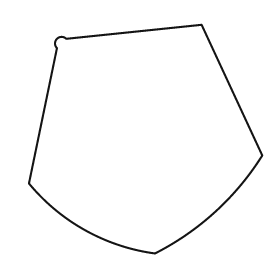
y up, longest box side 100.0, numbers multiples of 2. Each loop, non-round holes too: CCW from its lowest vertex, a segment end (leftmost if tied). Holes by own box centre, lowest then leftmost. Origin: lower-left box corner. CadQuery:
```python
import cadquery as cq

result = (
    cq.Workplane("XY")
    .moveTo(54.0, 0.0)
    .threePointArc((80.0, 18.0), (100.0, 42.0))
    .lineTo(74.0, 98.0)
    .lineTo(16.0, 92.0)
    .threePointArc((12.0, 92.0), (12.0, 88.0))
    .lineTo(0.0, 30.0)
    .threePointArc((24.0, 10.0), (54.0, 0.0))
    .close()
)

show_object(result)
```